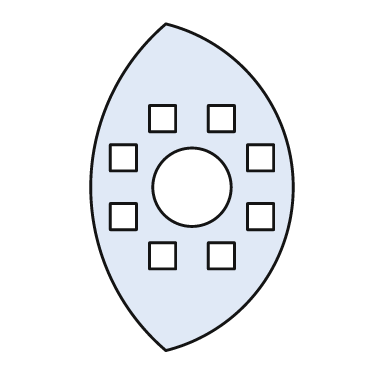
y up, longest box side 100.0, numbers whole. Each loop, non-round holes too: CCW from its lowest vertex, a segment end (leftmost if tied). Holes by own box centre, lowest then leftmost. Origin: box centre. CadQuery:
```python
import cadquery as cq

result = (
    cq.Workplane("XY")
    .moveTo(-8.0, -50.0)
    .threePointArc((31.0, 0.0), (-8.0, 50.0))
    .threePointArc((-31.0, 0.0), (-8.0, -50.0))
    .close()
    .moveTo(-13.0, -25.0)
    .lineTo(-5.0, -25.0)
    .lineTo(-5.0, -17.0)
    .lineTo(-13.0, -17.0)
    .close()
    .moveTo(5.0, -25.0)
    .lineTo(13.0, -25.0)
    .lineTo(13.0, -17.0)
    .lineTo(5.0, -17.0)
    .close()
    .moveTo(-25.0, -13.0)
    .lineTo(-17.0, -13.0)
    .lineTo(-17.0, -5.0)
    .lineTo(-25.0, -5.0)
    .close()
    .moveTo(17.0, -13.0)
    .lineTo(25.0, -13.0)
    .lineTo(25.0, -5.0)
    .lineTo(17.0, -5.0)
    .close()
    .moveTo(0.0, 0.0)
    .circle(12.0)
    .moveTo(-25.0, 5.0)
    .lineTo(-17.0, 5.0)
    .lineTo(-17.0, 13.0)
    .lineTo(-25.0, 13.0)
    .close()
    .moveTo(17.0, 5.0)
    .lineTo(25.0, 5.0)
    .lineTo(25.0, 13.0)
    .lineTo(17.0, 13.0)
    .close()
    .moveTo(-13.0, 17.0)
    .lineTo(-5.0, 17.0)
    .lineTo(-5.0, 25.0)
    .lineTo(-13.0, 25.0)
    .close()
    .moveTo(5.0, 17.0)
    .lineTo(13.0, 17.0)
    .lineTo(13.0, 25.0)
    .lineTo(5.0, 25.0)
    .close()
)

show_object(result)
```